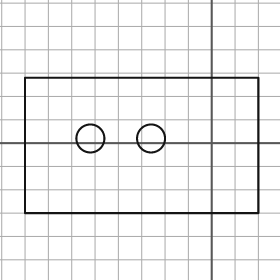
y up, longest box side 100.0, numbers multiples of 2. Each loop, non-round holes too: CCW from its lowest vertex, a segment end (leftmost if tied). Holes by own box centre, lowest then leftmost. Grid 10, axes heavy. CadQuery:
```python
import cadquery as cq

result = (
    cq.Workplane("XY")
    .moveTo(-80.0, -30.0)
    .lineTo(20.0, -30.0)
    .lineTo(20.0, 28.0)
    .lineTo(-80.0, 28.0)
    .close()
    .moveTo(-52.0, 2.0)
    .circle(6.0)
    .moveTo(-26.0, 2.0)
    .circle(6.0)
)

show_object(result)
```